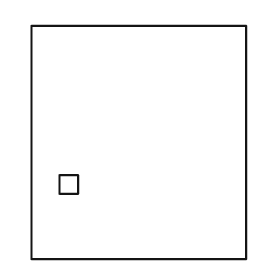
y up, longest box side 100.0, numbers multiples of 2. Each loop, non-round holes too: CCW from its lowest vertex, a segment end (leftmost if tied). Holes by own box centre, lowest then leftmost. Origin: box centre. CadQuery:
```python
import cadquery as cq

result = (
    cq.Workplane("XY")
    .moveTo(-46.0, -50.0)
    .lineTo(46.0, -50.0)
    .lineTo(46.0, 50.0)
    .lineTo(-46.0, 50.0)
    .close()
    .moveTo(-34.0, -22.0)
    .lineTo(-26.0, -22.0)
    .lineTo(-26.0, -14.0)
    .lineTo(-34.0, -14.0)
    .close()
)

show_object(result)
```